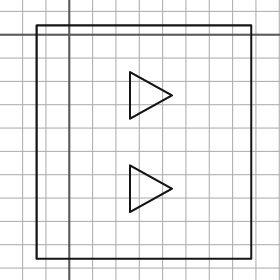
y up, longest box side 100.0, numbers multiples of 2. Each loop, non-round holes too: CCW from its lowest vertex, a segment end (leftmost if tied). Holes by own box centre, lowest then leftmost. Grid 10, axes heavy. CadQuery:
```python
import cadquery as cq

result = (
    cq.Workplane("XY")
    .moveTo(-14.0, -96.0)
    .lineTo(78.0, -96.0)
    .lineTo(78.0, 4.0)
    .lineTo(-14.0, 4.0)
    .close()
    .moveTo(26.0, -76.0)
    .lineTo(44.0, -66.0)
    .lineTo(26.0, -56.0)
    .close()
    .moveTo(26.0, -36.0)
    .lineTo(44.0, -26.0)
    .lineTo(26.0, -16.0)
    .close()
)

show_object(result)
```